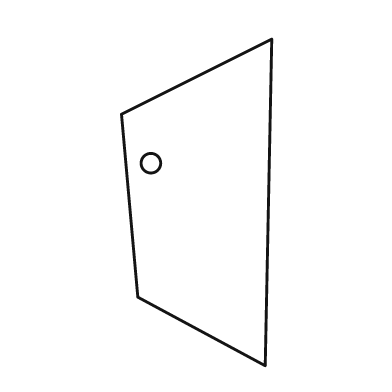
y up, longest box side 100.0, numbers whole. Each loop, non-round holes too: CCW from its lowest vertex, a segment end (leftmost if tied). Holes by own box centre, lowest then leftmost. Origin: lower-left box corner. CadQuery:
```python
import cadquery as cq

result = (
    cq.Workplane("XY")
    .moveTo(44.0, 0.0)
    .lineTo(46.0, 100.0)
    .lineTo(0.0, 77.0)
    .lineTo(5.0, 21.0)
    .close()
    .moveTo(9.0, 62.0)
    .circle(3.0)
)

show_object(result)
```